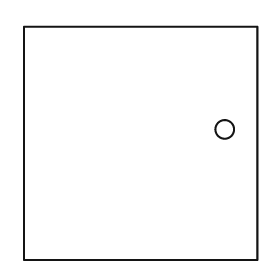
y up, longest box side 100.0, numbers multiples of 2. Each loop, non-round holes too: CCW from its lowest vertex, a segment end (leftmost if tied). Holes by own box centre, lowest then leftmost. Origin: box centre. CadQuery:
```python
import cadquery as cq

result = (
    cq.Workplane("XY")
    .moveTo(-50.0, -50.0)
    .lineTo(50.0, -50.0)
    .lineTo(50.0, 50.0)
    .lineTo(-50.0, 50.0)
    .close()
    .moveTo(36.0, 6.0)
    .circle(4.0)
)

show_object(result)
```